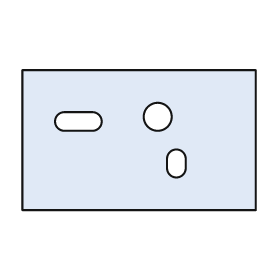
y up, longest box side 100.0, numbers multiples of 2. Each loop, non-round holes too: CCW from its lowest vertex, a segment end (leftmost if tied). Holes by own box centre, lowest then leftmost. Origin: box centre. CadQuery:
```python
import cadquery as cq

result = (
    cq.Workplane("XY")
    .moveTo(-50.0, -30.0)
    .lineTo(50.0, -30.0)
    .lineTo(50.0, 30.0)
    .lineTo(-50.0, 30.0)
    .close()
    .moveTo(12.0, -12.0)
    .threePointArc((16.0, -16.0), (20.0, -12.0))
    .lineTo(20.0, -8.0)
    .threePointArc((16.0, -4.0), (12.0, -8.0))
    .close()
    .moveTo(-32.0, 4.0)
    .lineTo(-20.0, 4.0)
    .threePointArc((-16.0, 8.0), (-20.0, 12.0))
    .lineTo(-32.0, 12.0)
    .threePointArc((-36.0, 8.0), (-32.0, 4.0))
    .close()
    .moveTo(8.0, 10.0)
    .circle(6.0)
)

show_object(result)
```